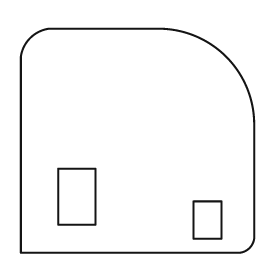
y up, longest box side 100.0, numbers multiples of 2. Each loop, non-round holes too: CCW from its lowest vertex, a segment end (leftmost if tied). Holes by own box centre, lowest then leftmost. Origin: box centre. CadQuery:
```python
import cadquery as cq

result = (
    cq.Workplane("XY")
    .moveTo(-50.0, -48.0)
    .lineTo(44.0, -48.0)
    .threePointArc((48.0, -46.0), (50.0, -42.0))
    .lineTo(50.0, 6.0)
    .threePointArc((38.0, 36.0), (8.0, 48.0))
    .lineTo(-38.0, 48.0)
    .threePointArc((-46.0, 44.0), (-50.0, 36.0))
    .close()
    .moveTo(24.0, -42.0)
    .lineTo(36.0, -42.0)
    .lineTo(36.0, -26.0)
    .lineTo(24.0, -26.0)
    .close()
    .moveTo(-34.0, -36.0)
    .lineTo(-18.0, -36.0)
    .lineTo(-18.0, -12.0)
    .lineTo(-34.0, -12.0)
    .close()
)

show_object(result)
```